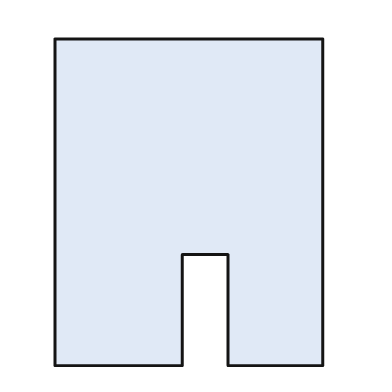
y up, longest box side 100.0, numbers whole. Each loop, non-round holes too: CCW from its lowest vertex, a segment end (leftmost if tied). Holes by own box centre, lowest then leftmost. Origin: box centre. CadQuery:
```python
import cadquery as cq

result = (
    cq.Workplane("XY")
    .moveTo(-41.0, -50.0)
    .lineTo(-2.0, -50.0)
    .lineTo(-2.0, -16.0)
    .lineTo(12.0, -16.0)
    .lineTo(12.0, -50.0)
    .lineTo(41.0, -50.0)
    .lineTo(41.0, 50.0)
    .lineTo(-41.0, 50.0)
    .close()
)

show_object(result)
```